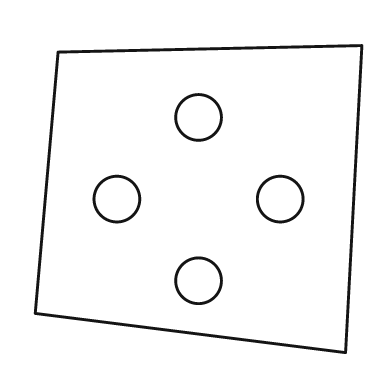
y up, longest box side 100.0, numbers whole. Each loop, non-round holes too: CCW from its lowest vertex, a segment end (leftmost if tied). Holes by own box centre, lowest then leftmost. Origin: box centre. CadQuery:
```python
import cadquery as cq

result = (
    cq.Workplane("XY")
    .moveTo(45.0, -47.0)
    .lineTo(50.0, 47.0)
    .lineTo(-43.0, 45.0)
    .lineTo(-50.0, -35.0)
    .close()
    .moveTo(0.0, -25.0)
    .circle(7.0)
    .moveTo(-25.0, 0.0)
    .circle(7.0)
    .moveTo(25.0, 0.0)
    .circle(7.0)
    .moveTo(0.0, 25.0)
    .circle(7.0)
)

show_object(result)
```